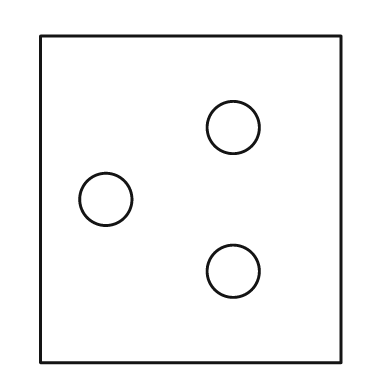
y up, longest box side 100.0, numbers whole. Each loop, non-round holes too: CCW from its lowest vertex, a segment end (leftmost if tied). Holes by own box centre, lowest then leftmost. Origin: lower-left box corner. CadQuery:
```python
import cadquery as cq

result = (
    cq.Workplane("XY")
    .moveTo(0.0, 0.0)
    .lineTo(92.0, 0.0)
    .lineTo(92.0, 100.0)
    .lineTo(0.0, 100.0)
    .close()
    .moveTo(59.0, 28.0)
    .circle(8.0)
    .moveTo(20.0, 50.0)
    .circle(8.0)
    .moveTo(59.0, 72.0)
    .circle(8.0)
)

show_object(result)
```